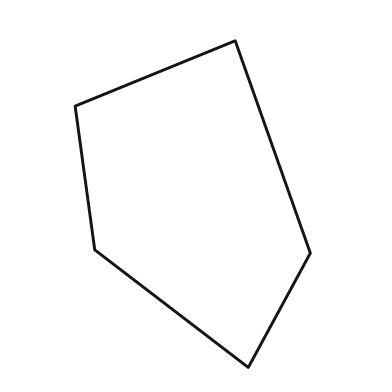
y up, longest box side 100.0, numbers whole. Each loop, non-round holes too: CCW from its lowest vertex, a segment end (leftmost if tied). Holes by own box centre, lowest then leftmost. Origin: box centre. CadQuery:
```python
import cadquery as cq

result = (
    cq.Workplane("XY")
    .moveTo(17.0, -50.0)
    .lineTo(36.0, -15.0)
    .lineTo(13.0, 50.0)
    .lineTo(-36.0, 30.0)
    .lineTo(-30.0, -14.0)
    .close()
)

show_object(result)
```